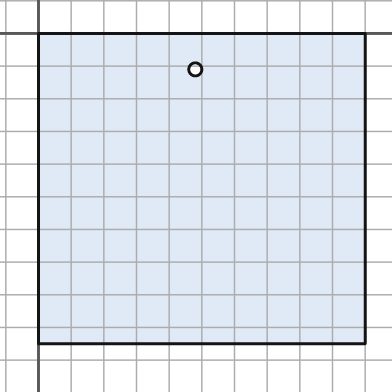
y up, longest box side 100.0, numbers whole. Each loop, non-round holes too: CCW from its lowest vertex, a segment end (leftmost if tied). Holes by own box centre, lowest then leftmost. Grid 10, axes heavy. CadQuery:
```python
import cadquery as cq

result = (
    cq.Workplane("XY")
    .moveTo(0.0, -95.0)
    .lineTo(100.0, -95.0)
    .lineTo(100.0, 0.0)
    .lineTo(0.0, 0.0)
    .close()
    .moveTo(48.0, -11.0)
    .circle(2.0)
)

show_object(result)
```